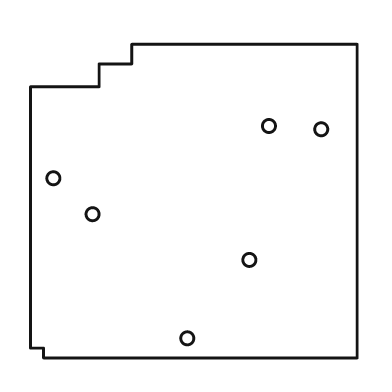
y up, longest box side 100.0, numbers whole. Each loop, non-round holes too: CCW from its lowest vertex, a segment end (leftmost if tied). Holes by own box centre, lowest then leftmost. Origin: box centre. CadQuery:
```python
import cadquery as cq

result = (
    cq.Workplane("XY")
    .moveTo(-46.0, -48.0)
    .lineTo(50.0, -48.0)
    .lineTo(50.0, 48.0)
    .lineTo(-19.0, 48.0)
    .lineTo(-19.0, 42.0)
    .lineTo(-29.0, 42.0)
    .lineTo(-29.0, 35.0)
    .lineTo(-50.0, 35.0)
    .lineTo(-50.0, -45.0)
    .lineTo(-46.0, -45.0)
    .close()
    .moveTo(-2.0, -42.0)
    .circle(2.0)
    .moveTo(17.0, -18.0)
    .circle(2.0)
    .moveTo(-31.0, -4.0)
    .circle(2.0)
    .moveTo(-43.0, 7.0)
    .circle(2.0)
    .moveTo(39.0, 22.0)
    .circle(2.0)
    .moveTo(23.0, 23.0)
    .circle(2.0)
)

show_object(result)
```